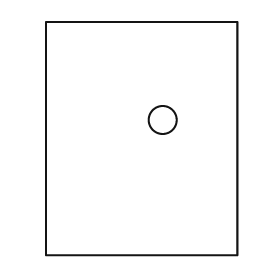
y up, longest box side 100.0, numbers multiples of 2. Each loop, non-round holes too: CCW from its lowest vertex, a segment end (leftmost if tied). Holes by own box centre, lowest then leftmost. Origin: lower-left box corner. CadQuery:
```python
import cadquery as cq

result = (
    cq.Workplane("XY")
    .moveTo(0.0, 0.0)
    .lineTo(82.0, 0.0)
    .lineTo(82.0, 100.0)
    .lineTo(0.0, 100.0)
    .close()
    .moveTo(50.0, 58.0)
    .circle(6.0)
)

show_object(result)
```